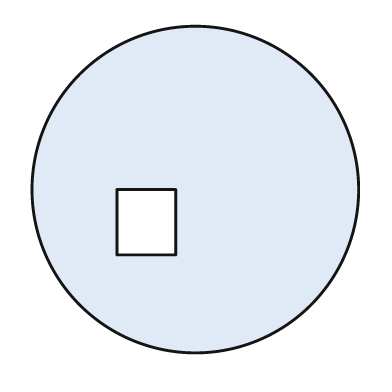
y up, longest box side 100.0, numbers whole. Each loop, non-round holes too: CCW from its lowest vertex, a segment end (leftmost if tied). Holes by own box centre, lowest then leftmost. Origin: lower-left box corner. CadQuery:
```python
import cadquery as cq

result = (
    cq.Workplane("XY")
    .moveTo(50.0, 50.0)
    .circle(50.0)
    .moveTo(26.0, 30.0)
    .lineTo(44.0, 30.0)
    .lineTo(44.0, 50.0)
    .lineTo(26.0, 50.0)
    .close()
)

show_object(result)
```